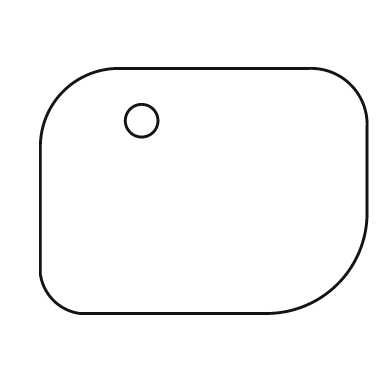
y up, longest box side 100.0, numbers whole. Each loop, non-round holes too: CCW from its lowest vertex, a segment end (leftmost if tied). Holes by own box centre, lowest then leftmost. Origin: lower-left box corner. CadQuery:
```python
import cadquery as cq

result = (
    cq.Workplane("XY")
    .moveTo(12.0, 0.0)
    .lineTo(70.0, 0.0)
    .threePointArc((91.0, 9.0), (100.0, 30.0))
    .lineTo(100.0, 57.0)
    .threePointArc((95.0, 70.0), (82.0, 75.0))
    .lineTo(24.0, 75.0)
    .threePointArc((7.0, 68.0), (0.0, 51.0))
    .lineTo(0.0, 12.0)
    .threePointArc((4.0, 4.0), (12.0, 0.0))
    .close()
    .moveTo(31.0, 59.0)
    .circle(5.0)
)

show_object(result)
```